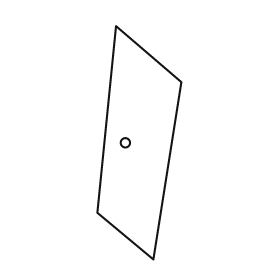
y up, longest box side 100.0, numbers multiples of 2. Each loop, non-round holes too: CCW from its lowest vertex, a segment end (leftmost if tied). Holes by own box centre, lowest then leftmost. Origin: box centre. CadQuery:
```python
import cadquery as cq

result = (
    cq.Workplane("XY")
    .moveTo(6.0, -50.0)
    .lineTo(18.0, 26.0)
    .lineTo(-10.0, 50.0)
    .lineTo(-18.0, -30.0)
    .close()
    .moveTo(-6.0, 0.0)
    .circle(2.0)
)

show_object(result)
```